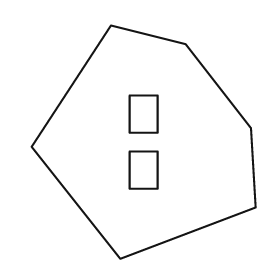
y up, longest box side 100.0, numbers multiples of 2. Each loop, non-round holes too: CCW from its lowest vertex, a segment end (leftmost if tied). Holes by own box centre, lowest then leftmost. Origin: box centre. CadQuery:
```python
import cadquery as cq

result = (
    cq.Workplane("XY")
    .moveTo(-10.0, -50.0)
    .lineTo(48.0, -28.0)
    .lineTo(46.0, 6.0)
    .lineTo(18.0, 42.0)
    .lineTo(-14.0, 50.0)
    .lineTo(-48.0, -2.0)
    .close()
    .moveTo(-6.0, -20.0)
    .lineTo(6.0, -20.0)
    .lineTo(6.0, -4.0)
    .lineTo(-6.0, -4.0)
    .close()
    .moveTo(-6.0, 4.0)
    .lineTo(6.0, 4.0)
    .lineTo(6.0, 20.0)
    .lineTo(-6.0, 20.0)
    .close()
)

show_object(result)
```